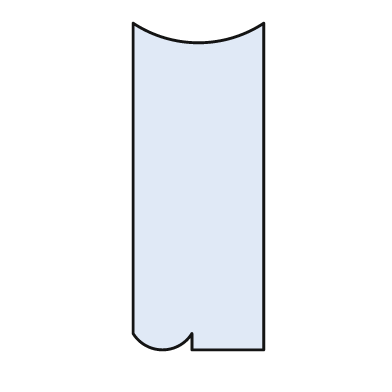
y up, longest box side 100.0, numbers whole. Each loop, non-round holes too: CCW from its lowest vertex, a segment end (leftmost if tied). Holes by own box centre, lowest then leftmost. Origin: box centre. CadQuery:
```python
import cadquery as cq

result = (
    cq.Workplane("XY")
    .moveTo(-2.0, -50.0)
    .lineTo(20.0, -50.0)
    .lineTo(20.0, 50.0)
    .threePointArc((0.0, 44.0), (-20.0, 50.0))
    .lineTo(-20.0, -45.0)
    .threePointArc((-11.0, -50.0), (-2.0, -45.0))
    .close()
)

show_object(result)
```